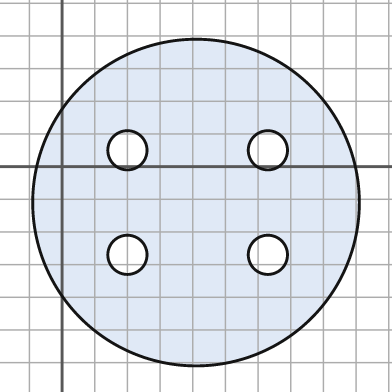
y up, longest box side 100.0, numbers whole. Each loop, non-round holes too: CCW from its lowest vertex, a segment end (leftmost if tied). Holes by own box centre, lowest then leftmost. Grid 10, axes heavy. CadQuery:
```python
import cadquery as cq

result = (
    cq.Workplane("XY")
    .moveTo(41.0, -11.0)
    .circle(50.0)
    .moveTo(20.0, -27.0)
    .circle(6.0)
    .moveTo(63.0, -27.0)
    .circle(6.0)
    .moveTo(20.0, 5.0)
    .circle(6.0)
    .moveTo(63.0, 5.0)
    .circle(6.0)
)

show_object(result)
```